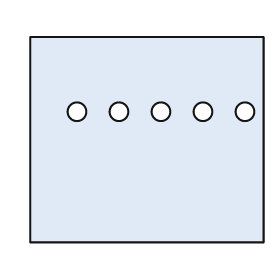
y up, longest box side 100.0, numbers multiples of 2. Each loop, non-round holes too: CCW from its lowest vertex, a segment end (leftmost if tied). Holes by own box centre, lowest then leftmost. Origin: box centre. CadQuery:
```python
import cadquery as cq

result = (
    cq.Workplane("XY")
    .moveTo(-50.0, -44.0)
    .lineTo(50.0, -44.0)
    .lineTo(50.0, 44.0)
    .lineTo(-50.0, 44.0)
    .close()
    .moveTo(-30.0, 12.0)
    .circle(4.0)
    .moveTo(-12.0, 12.0)
    .circle(4.0)
    .moveTo(6.0, 12.0)
    .circle(4.0)
    .moveTo(24.0, 12.0)
    .circle(4.0)
    .moveTo(42.0, 12.0)
    .circle(4.0)
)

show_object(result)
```